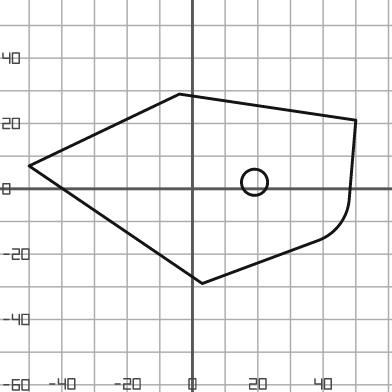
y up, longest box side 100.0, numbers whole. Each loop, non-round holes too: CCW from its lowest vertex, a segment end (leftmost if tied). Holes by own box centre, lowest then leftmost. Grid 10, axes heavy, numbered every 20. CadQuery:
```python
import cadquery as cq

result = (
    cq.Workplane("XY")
    .moveTo(3.0, -29.0)
    .lineTo(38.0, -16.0)
    .threePointArc((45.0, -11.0), (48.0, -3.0))
    .lineTo(50.0, 21.0)
    .lineTo(-4.0, 29.0)
    .lineTo(-50.0, 7.0)
    .close()
    .moveTo(19.0, 2.0)
    .circle(4.0)
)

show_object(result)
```